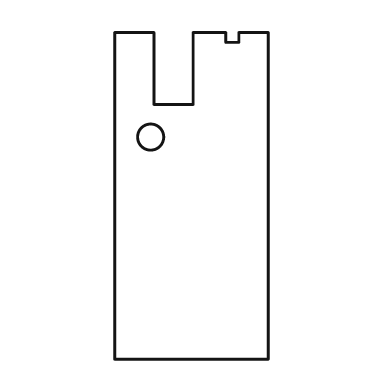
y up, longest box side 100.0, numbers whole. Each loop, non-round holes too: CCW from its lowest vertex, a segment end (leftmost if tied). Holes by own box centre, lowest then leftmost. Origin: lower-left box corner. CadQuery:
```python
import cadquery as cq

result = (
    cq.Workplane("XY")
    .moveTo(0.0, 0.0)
    .lineTo(47.0, 0.0)
    .lineTo(47.0, 100.0)
    .lineTo(38.0, 100.0)
    .lineTo(38.0, 97.0)
    .lineTo(34.0, 97.0)
    .lineTo(34.0, 100.0)
    .lineTo(24.0, 100.0)
    .lineTo(24.0, 78.0)
    .lineTo(12.0, 78.0)
    .lineTo(12.0, 100.0)
    .lineTo(0.0, 100.0)
    .close()
    .moveTo(11.0, 68.0)
    .circle(4.0)
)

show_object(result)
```